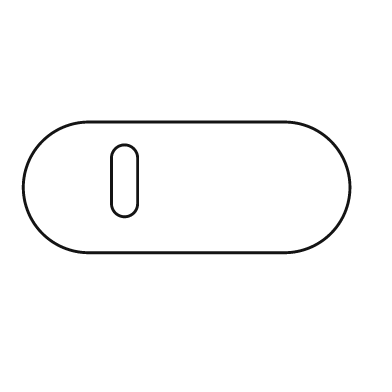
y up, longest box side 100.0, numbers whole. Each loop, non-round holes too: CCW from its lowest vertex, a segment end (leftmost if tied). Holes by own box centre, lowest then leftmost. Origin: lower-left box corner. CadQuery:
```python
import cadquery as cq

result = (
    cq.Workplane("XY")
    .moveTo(20.0, 0.0)
    .lineTo(80.0, 0.0)
    .threePointArc((100.0, 20.0), (80.0, 40.0))
    .lineTo(20.0, 40.0)
    .threePointArc((0.0, 20.0), (20.0, 0.0))
    .close()
    .moveTo(27.0, 15.0)
    .threePointArc((31.0, 11.0), (35.0, 15.0))
    .lineTo(35.0, 29.0)
    .threePointArc((31.0, 33.0), (27.0, 29.0))
    .close()
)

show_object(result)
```